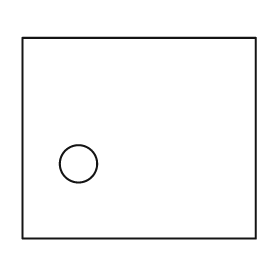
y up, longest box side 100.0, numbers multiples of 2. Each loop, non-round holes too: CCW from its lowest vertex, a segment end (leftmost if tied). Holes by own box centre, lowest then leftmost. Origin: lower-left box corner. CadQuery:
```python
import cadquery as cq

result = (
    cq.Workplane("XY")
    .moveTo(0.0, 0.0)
    .lineTo(100.0, 0.0)
    .lineTo(100.0, 86.0)
    .lineTo(0.0, 86.0)
    .close()
    .moveTo(24.0, 32.0)
    .circle(8.0)
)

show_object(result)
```